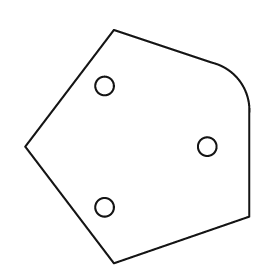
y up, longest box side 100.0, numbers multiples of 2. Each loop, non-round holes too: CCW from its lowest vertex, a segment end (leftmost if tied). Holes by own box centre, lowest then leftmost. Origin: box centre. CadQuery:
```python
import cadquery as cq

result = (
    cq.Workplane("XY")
    .moveTo(-10.0, -50.0)
    .lineTo(48.0, -30.0)
    .lineTo(48.0, 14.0)
    .threePointArc((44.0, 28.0), (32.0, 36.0))
    .lineTo(-10.0, 50.0)
    .lineTo(-48.0, 0.0)
    .close()
    .moveTo(-14.0, -26.0)
    .circle(4.0)
    .moveTo(30.0, 0.0)
    .circle(4.0)
    .moveTo(-14.0, 26.0)
    .circle(4.0)
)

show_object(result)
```